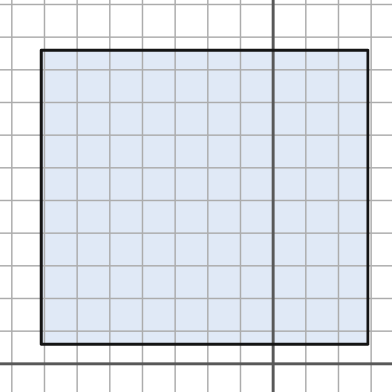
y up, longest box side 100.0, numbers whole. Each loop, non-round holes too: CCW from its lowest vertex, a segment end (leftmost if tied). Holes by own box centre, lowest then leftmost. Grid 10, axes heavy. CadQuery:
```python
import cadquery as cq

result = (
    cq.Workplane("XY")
    .moveTo(-71.0, 6.0)
    .lineTo(29.0, 6.0)
    .lineTo(29.0, 96.0)
    .lineTo(-71.0, 96.0)
    .close()
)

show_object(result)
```